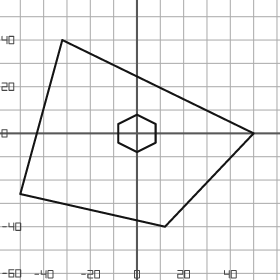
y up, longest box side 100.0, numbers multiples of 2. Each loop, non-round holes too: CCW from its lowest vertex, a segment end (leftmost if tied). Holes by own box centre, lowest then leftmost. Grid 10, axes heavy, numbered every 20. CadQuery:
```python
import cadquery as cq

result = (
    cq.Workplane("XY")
    .moveTo(12.0, -40.0)
    .lineTo(50.0, 0.0)
    .lineTo(-32.0, 40.0)
    .lineTo(-50.0, -26.0)
    .close()
    .moveTo(0.0, -8.0)
    .lineTo(8.0, -4.0)
    .lineTo(8.0, 4.0)
    .lineTo(0.0, 8.0)
    .lineTo(-8.0, 4.0)
    .lineTo(-8.0, -4.0)
    .close()
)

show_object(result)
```